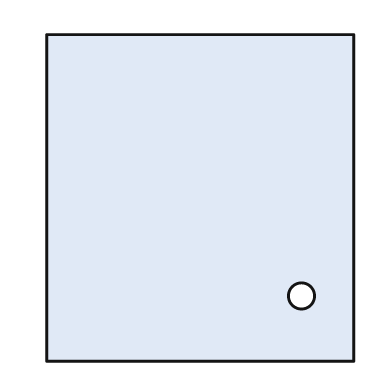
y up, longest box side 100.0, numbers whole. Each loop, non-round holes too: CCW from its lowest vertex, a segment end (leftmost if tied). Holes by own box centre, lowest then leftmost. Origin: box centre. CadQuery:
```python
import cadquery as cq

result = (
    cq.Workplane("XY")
    .moveTo(-47.0, -50.0)
    .lineTo(47.0, -50.0)
    .lineTo(47.0, 50.0)
    .lineTo(-47.0, 50.0)
    .close()
    .moveTo(31.0, -30.0)
    .circle(4.0)
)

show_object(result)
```